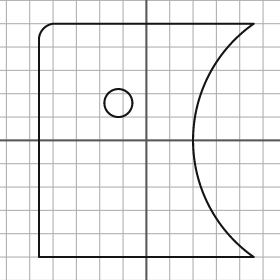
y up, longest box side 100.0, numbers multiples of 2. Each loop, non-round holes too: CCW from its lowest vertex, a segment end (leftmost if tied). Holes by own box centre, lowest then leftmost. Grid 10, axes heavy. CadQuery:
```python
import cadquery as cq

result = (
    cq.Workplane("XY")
    .moveTo(-46.0, -50.0)
    .lineTo(46.0, -50.0)
    .threePointArc((20.0, 0.0), (46.0, 50.0))
    .lineTo(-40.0, 50.0)
    .threePointArc((-44.0, 48.0), (-46.0, 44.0))
    .close()
    .moveTo(-12.0, 16.0)
    .circle(6.0)
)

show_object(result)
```